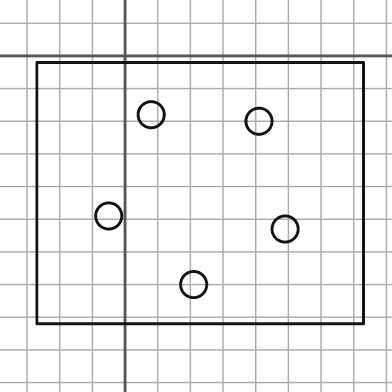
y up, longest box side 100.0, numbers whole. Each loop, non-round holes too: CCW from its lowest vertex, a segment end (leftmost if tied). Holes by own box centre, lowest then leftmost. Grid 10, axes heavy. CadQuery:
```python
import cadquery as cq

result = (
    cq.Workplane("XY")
    .moveTo(-27.0, -82.0)
    .lineTo(73.0, -82.0)
    .lineTo(73.0, -2.0)
    .lineTo(-27.0, -2.0)
    .close()
    .moveTo(21.0, -70.0)
    .circle(4.0)
    .moveTo(49.0, -53.0)
    .circle(4.0)
    .moveTo(-5.0, -49.0)
    .circle(4.0)
    .moveTo(41.0, -20.0)
    .circle(4.0)
    .moveTo(8.0, -18.0)
    .circle(4.0)
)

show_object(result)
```